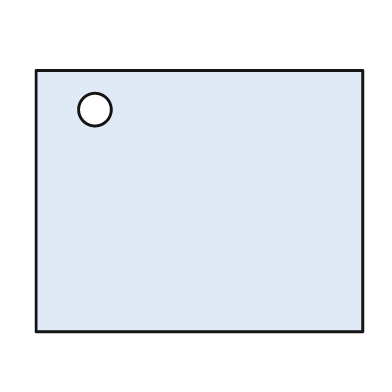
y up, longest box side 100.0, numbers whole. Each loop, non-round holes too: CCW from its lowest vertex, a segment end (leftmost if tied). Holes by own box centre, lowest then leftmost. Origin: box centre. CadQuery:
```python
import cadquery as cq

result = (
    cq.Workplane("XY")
    .moveTo(-50.0, -40.0)
    .lineTo(50.0, -40.0)
    .lineTo(50.0, 40.0)
    .lineTo(-50.0, 40.0)
    .close()
    .moveTo(-32.0, 28.0)
    .circle(5.0)
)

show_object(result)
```